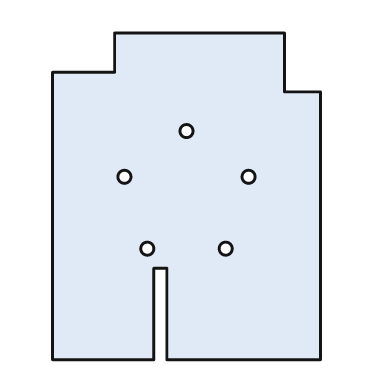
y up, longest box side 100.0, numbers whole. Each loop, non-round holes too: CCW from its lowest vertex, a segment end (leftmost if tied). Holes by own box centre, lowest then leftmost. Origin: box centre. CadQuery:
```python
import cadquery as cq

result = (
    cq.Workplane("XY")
    .moveTo(-41.0, -50.0)
    .lineTo(-10.0, -50.0)
    .lineTo(-10.0, -22.0)
    .lineTo(-6.0, -22.0)
    .lineTo(-6.0, -50.0)
    .lineTo(41.0, -50.0)
    .lineTo(41.0, 32.0)
    .lineTo(30.0, 32.0)
    .lineTo(30.0, 50.0)
    .lineTo(-22.0, 50.0)
    .lineTo(-22.0, 38.0)
    .lineTo(-41.0, 38.0)
    .close()
    .moveTo(-12.0, -16.0)
    .circle(2.0)
    .moveTo(12.0, -16.0)
    .circle(2.0)
    .moveTo(-19.0, 6.0)
    .circle(2.0)
    .moveTo(19.0, 6.0)
    .circle(2.0)
    .moveTo(0.0, 20.0)
    .circle(2.0)
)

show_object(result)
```